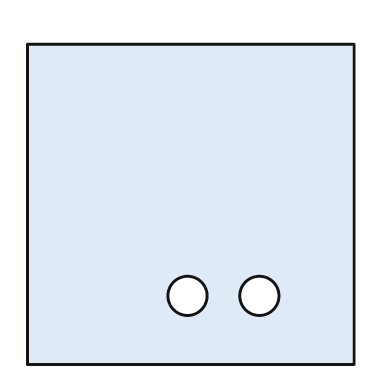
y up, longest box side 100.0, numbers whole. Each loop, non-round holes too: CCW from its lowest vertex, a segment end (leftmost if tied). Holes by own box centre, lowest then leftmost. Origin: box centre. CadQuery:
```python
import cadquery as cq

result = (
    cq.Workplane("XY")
    .moveTo(-50.0, -49.0)
    .lineTo(50.0, -49.0)
    .lineTo(50.0, 49.0)
    .lineTo(-50.0, 49.0)
    .close()
    .moveTo(-1.0, -28.0)
    .circle(6.0)
    .moveTo(21.0, -28.0)
    .circle(6.0)
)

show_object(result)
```